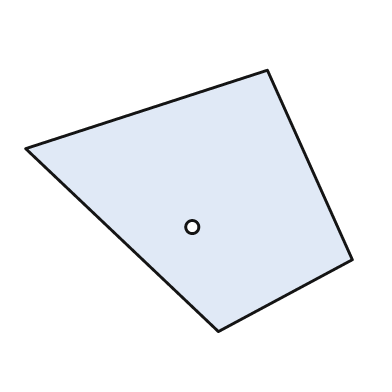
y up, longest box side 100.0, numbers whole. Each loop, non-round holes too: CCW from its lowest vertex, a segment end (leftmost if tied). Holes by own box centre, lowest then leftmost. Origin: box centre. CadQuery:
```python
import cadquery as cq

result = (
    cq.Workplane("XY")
    .moveTo(9.0, -40.0)
    .lineTo(50.0, -18.0)
    .lineTo(24.0, 40.0)
    .lineTo(-50.0, 16.0)
    .close()
    .moveTo(1.0, -8.0)
    .circle(2.0)
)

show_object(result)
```